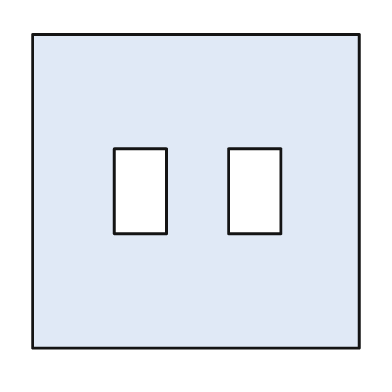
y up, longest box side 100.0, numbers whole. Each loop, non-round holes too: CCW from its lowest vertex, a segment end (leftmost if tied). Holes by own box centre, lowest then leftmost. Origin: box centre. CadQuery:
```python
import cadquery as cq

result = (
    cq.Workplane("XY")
    .moveTo(-50.0, -48.0)
    .lineTo(50.0, -48.0)
    .lineTo(50.0, 48.0)
    .lineTo(-50.0, 48.0)
    .close()
    .moveTo(-25.0, -13.0)
    .lineTo(-9.0, -13.0)
    .lineTo(-9.0, 13.0)
    .lineTo(-25.0, 13.0)
    .close()
    .moveTo(10.0, -13.0)
    .lineTo(26.0, -13.0)
    .lineTo(26.0, 13.0)
    .lineTo(10.0, 13.0)
    .close()
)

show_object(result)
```